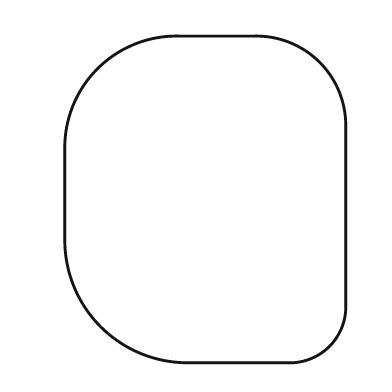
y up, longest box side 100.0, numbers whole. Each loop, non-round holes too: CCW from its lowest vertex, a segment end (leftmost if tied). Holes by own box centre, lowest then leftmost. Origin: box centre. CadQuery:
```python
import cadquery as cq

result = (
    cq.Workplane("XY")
    .moveTo(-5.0, -50.0)
    .lineTo(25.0, -50.0)
    .threePointArc((38.0, -45.0), (43.0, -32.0))
    .lineTo(43.0, 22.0)
    .threePointArc((35.0, 42.0), (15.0, 50.0))
    .lineTo(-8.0, 50.0)
    .threePointArc((-33.0, 40.0), (-43.0, 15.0))
    .lineTo(-43.0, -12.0)
    .threePointArc((-32.0, -39.0), (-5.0, -50.0))
    .close()
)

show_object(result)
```